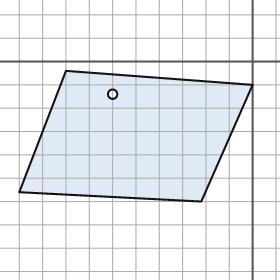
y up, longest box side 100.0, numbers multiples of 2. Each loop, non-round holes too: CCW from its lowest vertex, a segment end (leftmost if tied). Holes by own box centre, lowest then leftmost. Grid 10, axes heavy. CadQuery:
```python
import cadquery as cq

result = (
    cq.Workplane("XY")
    .moveTo(-22.0, -60.0)
    .lineTo(0.0, -10.0)
    .lineTo(-80.0, -4.0)
    .lineTo(-100.0, -56.0)
    .close()
    .moveTo(-60.0, -14.0)
    .circle(2.0)
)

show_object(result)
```